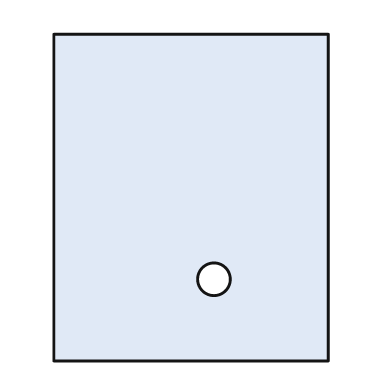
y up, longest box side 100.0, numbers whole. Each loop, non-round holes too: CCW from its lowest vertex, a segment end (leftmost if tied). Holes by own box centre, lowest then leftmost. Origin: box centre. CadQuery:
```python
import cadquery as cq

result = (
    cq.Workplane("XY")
    .moveTo(-42.0, -50.0)
    .lineTo(42.0, -50.0)
    .lineTo(42.0, 50.0)
    .lineTo(-42.0, 50.0)
    .close()
    .moveTo(7.0, -25.0)
    .circle(5.0)
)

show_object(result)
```